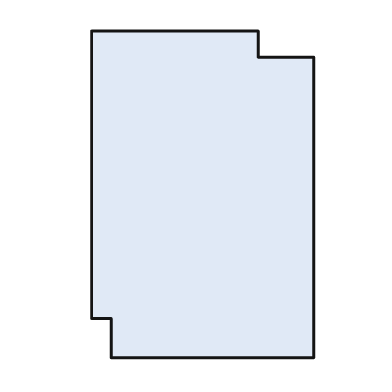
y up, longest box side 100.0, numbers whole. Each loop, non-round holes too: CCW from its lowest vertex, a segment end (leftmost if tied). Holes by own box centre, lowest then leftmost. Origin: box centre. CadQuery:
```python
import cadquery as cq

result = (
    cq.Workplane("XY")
    .moveTo(-28.0, -50.0)
    .lineTo(34.0, -50.0)
    .lineTo(34.0, 42.0)
    .lineTo(17.0, 42.0)
    .lineTo(17.0, 50.0)
    .lineTo(-34.0, 50.0)
    .lineTo(-34.0, -38.0)
    .lineTo(-28.0, -38.0)
    .close()
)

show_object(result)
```